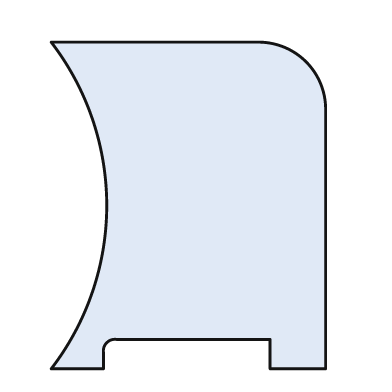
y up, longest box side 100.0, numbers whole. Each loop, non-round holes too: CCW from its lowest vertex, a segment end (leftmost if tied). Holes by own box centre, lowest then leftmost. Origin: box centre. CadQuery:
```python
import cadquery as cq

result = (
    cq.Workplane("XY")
    .moveTo(-42.0, -50.0)
    .lineTo(-26.0, -50.0)
    .lineTo(-26.0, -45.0)
    .threePointArc((-25.0, -42.0), (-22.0, -41.0))
    .lineTo(25.0, -41.0)
    .lineTo(25.0, -50.0)
    .lineTo(42.0, -50.0)
    .lineTo(42.0, 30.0)
    .threePointArc((36.0, 44.0), (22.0, 50.0))
    .lineTo(-42.0, 50.0)
    .threePointArc((-25.0, 0.0), (-42.0, -50.0))
    .close()
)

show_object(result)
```